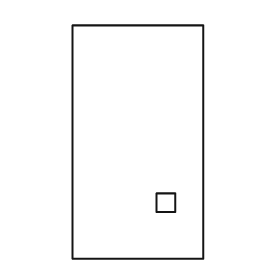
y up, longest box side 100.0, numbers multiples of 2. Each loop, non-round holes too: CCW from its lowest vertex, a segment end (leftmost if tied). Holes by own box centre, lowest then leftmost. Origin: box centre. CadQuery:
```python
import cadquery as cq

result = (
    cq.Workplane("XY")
    .moveTo(-28.0, -50.0)
    .lineTo(28.0, -50.0)
    .lineTo(28.0, 50.0)
    .lineTo(-28.0, 50.0)
    .close()
    .moveTo(8.0, -30.0)
    .lineTo(16.0, -30.0)
    .lineTo(16.0, -22.0)
    .lineTo(8.0, -22.0)
    .close()
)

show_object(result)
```